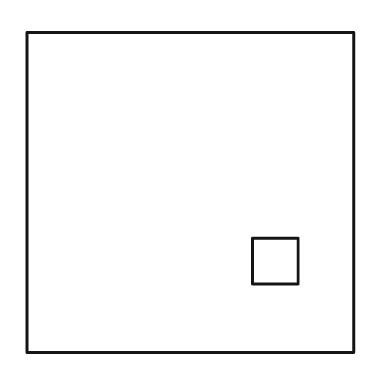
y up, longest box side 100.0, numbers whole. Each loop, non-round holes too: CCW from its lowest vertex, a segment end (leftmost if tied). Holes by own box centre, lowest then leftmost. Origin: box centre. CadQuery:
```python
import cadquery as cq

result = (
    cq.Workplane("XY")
    .moveTo(-50.0, -49.0)
    .lineTo(50.0, -49.0)
    .lineTo(50.0, 49.0)
    .lineTo(-50.0, 49.0)
    .close()
    .moveTo(19.0, -28.0)
    .lineTo(33.0, -28.0)
    .lineTo(33.0, -14.0)
    .lineTo(19.0, -14.0)
    .close()
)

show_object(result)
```